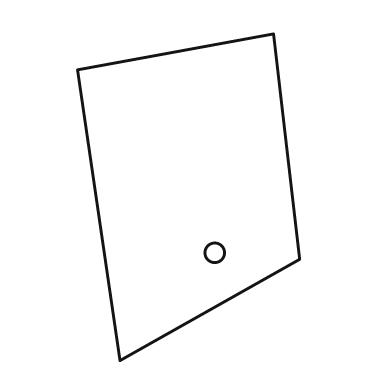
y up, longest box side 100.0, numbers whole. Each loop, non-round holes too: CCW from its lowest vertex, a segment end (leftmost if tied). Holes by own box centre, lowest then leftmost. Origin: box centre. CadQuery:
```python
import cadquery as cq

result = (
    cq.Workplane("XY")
    .moveTo(-21.0, -50.0)
    .lineTo(34.0, -19.0)
    .lineTo(26.0, 50.0)
    .lineTo(-34.0, 39.0)
    .close()
    .moveTo(8.0, -17.0)
    .circle(3.0)
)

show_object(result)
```